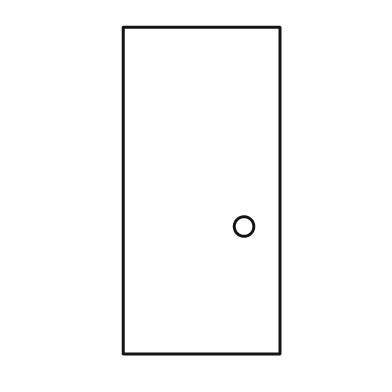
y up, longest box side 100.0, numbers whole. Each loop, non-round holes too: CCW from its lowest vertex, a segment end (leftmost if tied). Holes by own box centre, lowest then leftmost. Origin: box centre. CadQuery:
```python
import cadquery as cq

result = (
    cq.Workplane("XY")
    .moveTo(-24.0, -50.0)
    .lineTo(24.0, -50.0)
    .lineTo(24.0, 50.0)
    .lineTo(-24.0, 50.0)
    .close()
    .moveTo(13.0, -11.0)
    .circle(3.0)
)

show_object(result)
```